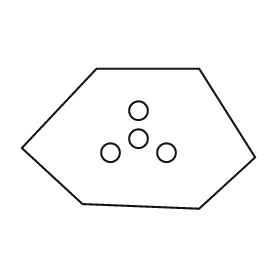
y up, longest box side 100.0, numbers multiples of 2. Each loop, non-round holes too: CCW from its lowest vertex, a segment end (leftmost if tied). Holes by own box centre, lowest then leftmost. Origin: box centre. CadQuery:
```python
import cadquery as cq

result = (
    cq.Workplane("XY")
    .moveTo(26.0, -30.0)
    .lineTo(50.0, -8.0)
    .lineTo(26.0, 30.0)
    .lineTo(-18.0, 30.0)
    .lineTo(-50.0, -4.0)
    .lineTo(-24.0, -28.0)
    .close()
    .moveTo(-12.0, -6.0)
    .circle(4.0)
    .moveTo(12.0, -6.0)
    .circle(4.0)
    .moveTo(0.0, 0.0)
    .circle(4.0)
    .moveTo(0.0, 12.0)
    .circle(4.0)
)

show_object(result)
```